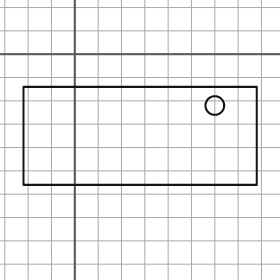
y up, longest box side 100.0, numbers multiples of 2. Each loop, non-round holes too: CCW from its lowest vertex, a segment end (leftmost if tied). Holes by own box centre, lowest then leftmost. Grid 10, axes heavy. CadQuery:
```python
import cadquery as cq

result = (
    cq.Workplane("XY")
    .moveTo(-22.0, -56.0)
    .lineTo(78.0, -56.0)
    .lineTo(78.0, -14.0)
    .lineTo(-22.0, -14.0)
    .close()
    .moveTo(60.0, -22.0)
    .circle(4.0)
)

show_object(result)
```